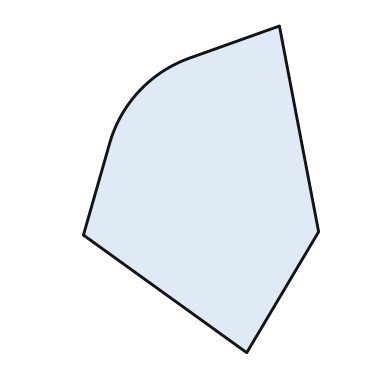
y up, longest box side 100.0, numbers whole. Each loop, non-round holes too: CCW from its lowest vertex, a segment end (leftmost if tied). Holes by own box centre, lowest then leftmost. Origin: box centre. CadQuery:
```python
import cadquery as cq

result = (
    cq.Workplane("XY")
    .moveTo(14.0, -50.0)
    .lineTo(36.0, -13.0)
    .lineTo(24.0, 50.0)
    .lineTo(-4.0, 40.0)
    .threePointArc((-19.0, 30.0), (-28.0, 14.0))
    .lineTo(-36.0, -14.0)
    .close()
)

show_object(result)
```